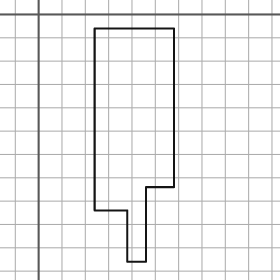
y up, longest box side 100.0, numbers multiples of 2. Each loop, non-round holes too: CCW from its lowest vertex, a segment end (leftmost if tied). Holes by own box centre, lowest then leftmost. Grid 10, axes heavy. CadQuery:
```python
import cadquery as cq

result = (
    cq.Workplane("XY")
    .moveTo(38.0, -106.0)
    .lineTo(46.0, -106.0)
    .lineTo(46.0, -74.0)
    .lineTo(58.0, -74.0)
    .lineTo(58.0, -6.0)
    .lineTo(24.0, -6.0)
    .lineTo(24.0, -84.0)
    .lineTo(38.0, -84.0)
    .close()
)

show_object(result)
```